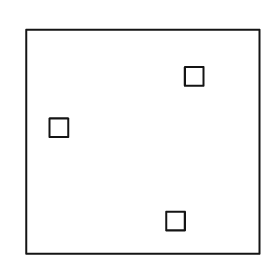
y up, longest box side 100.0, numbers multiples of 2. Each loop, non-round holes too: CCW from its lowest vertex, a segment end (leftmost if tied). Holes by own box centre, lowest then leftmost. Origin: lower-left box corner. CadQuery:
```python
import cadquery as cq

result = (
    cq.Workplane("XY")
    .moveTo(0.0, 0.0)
    .lineTo(100.0, 0.0)
    .lineTo(100.0, 96.0)
    .lineTo(0.0, 96.0)
    .close()
    .moveTo(60.0, 10.0)
    .lineTo(68.0, 10.0)
    .lineTo(68.0, 18.0)
    .lineTo(60.0, 18.0)
    .close()
    .moveTo(10.0, 50.0)
    .lineTo(18.0, 50.0)
    .lineTo(18.0, 58.0)
    .lineTo(10.0, 58.0)
    .close()
    .moveTo(68.0, 72.0)
    .lineTo(76.0, 72.0)
    .lineTo(76.0, 80.0)
    .lineTo(68.0, 80.0)
    .close()
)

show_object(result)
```